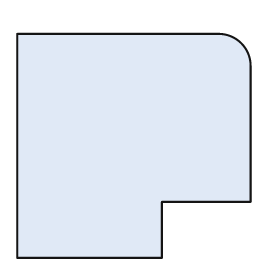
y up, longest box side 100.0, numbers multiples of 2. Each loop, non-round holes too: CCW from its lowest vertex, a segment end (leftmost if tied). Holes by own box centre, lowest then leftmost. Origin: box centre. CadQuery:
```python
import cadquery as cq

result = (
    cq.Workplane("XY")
    .moveTo(-50.0, -48.0)
    .lineTo(12.0, -48.0)
    .lineTo(12.0, -24.0)
    .lineTo(50.0, -24.0)
    .lineTo(50.0, 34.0)
    .threePointArc((46.0, 44.0), (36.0, 48.0))
    .lineTo(-50.0, 48.0)
    .close()
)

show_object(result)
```